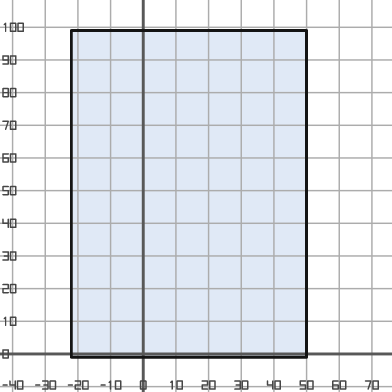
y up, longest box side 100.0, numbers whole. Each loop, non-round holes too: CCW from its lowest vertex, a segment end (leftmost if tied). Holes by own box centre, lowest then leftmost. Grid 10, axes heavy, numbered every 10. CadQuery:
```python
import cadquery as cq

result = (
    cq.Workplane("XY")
    .moveTo(-22.0, -1.0)
    .lineTo(50.0, -1.0)
    .lineTo(50.0, 99.0)
    .lineTo(-22.0, 99.0)
    .close()
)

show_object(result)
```